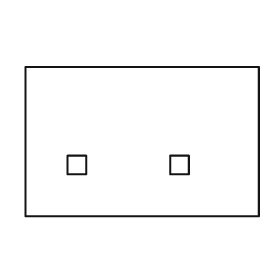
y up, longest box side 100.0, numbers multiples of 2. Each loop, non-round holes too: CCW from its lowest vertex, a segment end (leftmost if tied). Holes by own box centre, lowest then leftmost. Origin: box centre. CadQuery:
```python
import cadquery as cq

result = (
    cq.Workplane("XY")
    .moveTo(-50.0, -32.0)
    .lineTo(50.0, -32.0)
    .lineTo(50.0, 32.0)
    .lineTo(-50.0, 32.0)
    .close()
    .moveTo(-32.0, -14.0)
    .lineTo(-24.0, -14.0)
    .lineTo(-24.0, -6.0)
    .lineTo(-32.0, -6.0)
    .close()
    .moveTo(12.0, -14.0)
    .lineTo(20.0, -14.0)
    .lineTo(20.0, -6.0)
    .lineTo(12.0, -6.0)
    .close()
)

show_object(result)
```